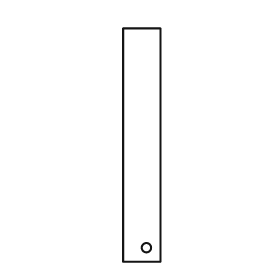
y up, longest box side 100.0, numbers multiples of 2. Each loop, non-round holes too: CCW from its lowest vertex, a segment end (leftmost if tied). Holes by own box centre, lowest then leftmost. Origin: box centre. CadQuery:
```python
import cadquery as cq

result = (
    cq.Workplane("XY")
    .moveTo(-8.0, -50.0)
    .lineTo(8.0, -50.0)
    .lineTo(8.0, 50.0)
    .lineTo(-8.0, 50.0)
    .close()
    .moveTo(2.0, -44.0)
    .circle(2.0)
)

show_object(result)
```